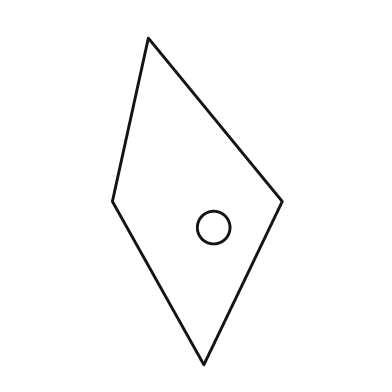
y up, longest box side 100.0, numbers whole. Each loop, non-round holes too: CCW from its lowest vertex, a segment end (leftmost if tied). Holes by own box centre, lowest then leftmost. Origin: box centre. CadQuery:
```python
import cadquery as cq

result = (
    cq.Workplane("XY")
    .moveTo(2.0, -50.0)
    .lineTo(26.0, 0.0)
    .lineTo(-15.0, 50.0)
    .lineTo(-26.0, 0.0)
    .close()
    .moveTo(5.0, -8.0)
    .circle(5.0)
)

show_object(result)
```